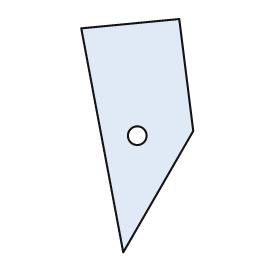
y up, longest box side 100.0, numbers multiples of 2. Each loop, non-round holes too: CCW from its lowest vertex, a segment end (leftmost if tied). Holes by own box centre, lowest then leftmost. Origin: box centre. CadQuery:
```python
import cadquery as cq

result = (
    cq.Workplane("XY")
    .moveTo(-6.0, -50.0)
    .lineTo(24.0, 2.0)
    .lineTo(18.0, 50.0)
    .lineTo(-24.0, 46.0)
    .close()
    .moveTo(0.0, 0.0)
    .circle(4.0)
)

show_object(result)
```